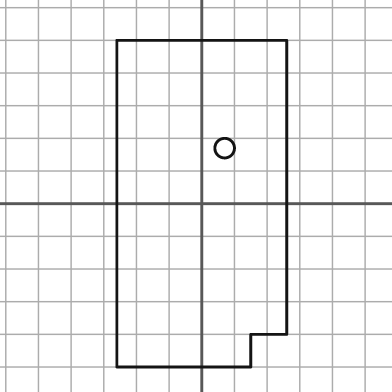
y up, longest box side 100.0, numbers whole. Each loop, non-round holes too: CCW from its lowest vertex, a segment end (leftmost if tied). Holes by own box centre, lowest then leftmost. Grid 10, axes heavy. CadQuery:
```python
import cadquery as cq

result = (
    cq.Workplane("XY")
    .moveTo(-26.0, -50.0)
    .lineTo(15.0, -50.0)
    .lineTo(15.0, -40.0)
    .lineTo(26.0, -40.0)
    .lineTo(26.0, 50.0)
    .lineTo(-26.0, 50.0)
    .close()
    .moveTo(7.0, 17.0)
    .circle(3.0)
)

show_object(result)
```